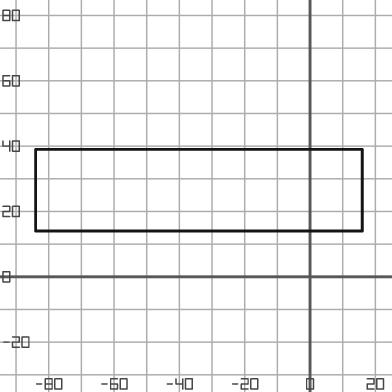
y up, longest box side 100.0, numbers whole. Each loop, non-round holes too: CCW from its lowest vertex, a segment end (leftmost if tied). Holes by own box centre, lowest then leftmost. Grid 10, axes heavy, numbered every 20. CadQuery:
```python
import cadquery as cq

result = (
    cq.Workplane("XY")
    .moveTo(-84.0, 14.0)
    .lineTo(16.0, 14.0)
    .lineTo(16.0, 39.0)
    .lineTo(-84.0, 39.0)
    .close()
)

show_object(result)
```